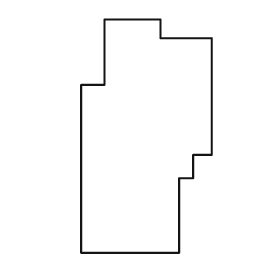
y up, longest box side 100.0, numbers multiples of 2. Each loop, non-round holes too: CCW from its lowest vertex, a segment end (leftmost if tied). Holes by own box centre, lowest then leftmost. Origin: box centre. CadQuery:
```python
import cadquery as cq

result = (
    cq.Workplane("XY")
    .moveTo(-28.0, -50.0)
    .lineTo(14.0, -50.0)
    .lineTo(14.0, -18.0)
    .lineTo(20.0, -18.0)
    .lineTo(20.0, -8.0)
    .lineTo(28.0, -8.0)
    .lineTo(28.0, 42.0)
    .lineTo(6.0, 42.0)
    .lineTo(6.0, 50.0)
    .lineTo(-18.0, 50.0)
    .lineTo(-18.0, 22.0)
    .lineTo(-28.0, 22.0)
    .close()
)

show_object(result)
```